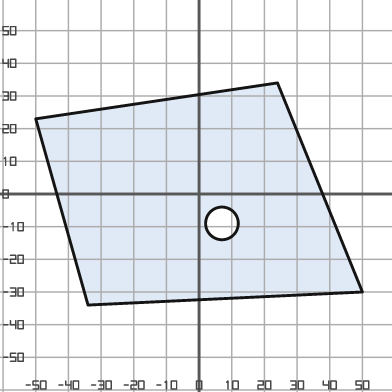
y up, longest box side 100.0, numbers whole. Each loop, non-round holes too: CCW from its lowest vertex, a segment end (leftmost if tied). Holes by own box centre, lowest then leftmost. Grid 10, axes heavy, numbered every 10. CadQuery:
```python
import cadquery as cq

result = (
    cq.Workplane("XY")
    .moveTo(-34.0, -34.0)
    .lineTo(50.0, -30.0)
    .lineTo(24.0, 34.0)
    .lineTo(-50.0, 23.0)
    .close()
    .moveTo(7.0, -9.0)
    .circle(5.0)
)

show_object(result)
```